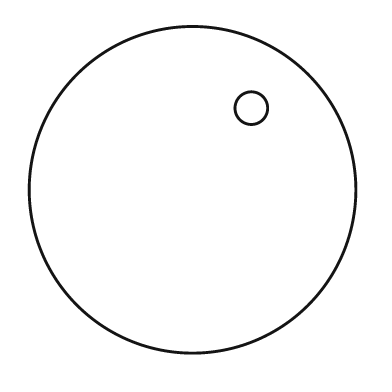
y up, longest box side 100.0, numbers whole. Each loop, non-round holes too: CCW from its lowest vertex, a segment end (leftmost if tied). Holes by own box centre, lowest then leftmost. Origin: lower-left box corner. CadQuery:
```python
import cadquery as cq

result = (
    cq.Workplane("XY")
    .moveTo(50.0, 50.0)
    .circle(50.0)
    .moveTo(68.0, 75.0)
    .circle(5.0)
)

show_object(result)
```